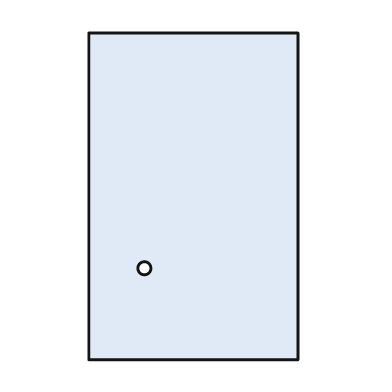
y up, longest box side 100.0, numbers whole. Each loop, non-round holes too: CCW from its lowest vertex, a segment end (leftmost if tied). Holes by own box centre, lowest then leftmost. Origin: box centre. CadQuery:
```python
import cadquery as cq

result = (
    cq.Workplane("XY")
    .moveTo(-32.0, -50.0)
    .lineTo(32.0, -50.0)
    .lineTo(32.0, 50.0)
    .lineTo(-32.0, 50.0)
    .close()
    .moveTo(-15.0, -22.0)
    .circle(2.0)
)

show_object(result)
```